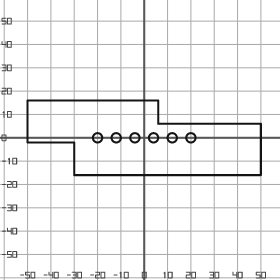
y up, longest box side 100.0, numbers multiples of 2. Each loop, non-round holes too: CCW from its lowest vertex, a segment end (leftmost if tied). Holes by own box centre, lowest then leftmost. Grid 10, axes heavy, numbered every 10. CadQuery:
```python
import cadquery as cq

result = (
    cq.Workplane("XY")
    .moveTo(-30.0, -16.0)
    .lineTo(50.0, -16.0)
    .lineTo(50.0, 6.0)
    .lineTo(6.0, 6.0)
    .lineTo(6.0, 16.0)
    .lineTo(-50.0, 16.0)
    .lineTo(-50.0, -2.0)
    .lineTo(-30.0, -2.0)
    .close()
    .moveTo(-20.0, 0.0)
    .circle(2.0)
    .moveTo(-12.0, 0.0)
    .circle(2.0)
    .moveTo(-4.0, 0.0)
    .circle(2.0)
    .moveTo(4.0, 0.0)
    .circle(2.0)
    .moveTo(12.0, 0.0)
    .circle(2.0)
    .moveTo(20.0, 0.0)
    .circle(2.0)
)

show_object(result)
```